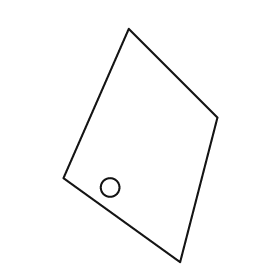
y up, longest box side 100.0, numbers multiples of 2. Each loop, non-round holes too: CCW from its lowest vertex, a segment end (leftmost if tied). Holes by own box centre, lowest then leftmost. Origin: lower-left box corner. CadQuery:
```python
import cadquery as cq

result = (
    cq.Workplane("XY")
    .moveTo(50.0, 0.0)
    .lineTo(66.0, 62.0)
    .lineTo(28.0, 100.0)
    .lineTo(0.0, 36.0)
    .close()
    .moveTo(20.0, 32.0)
    .circle(4.0)
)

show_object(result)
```